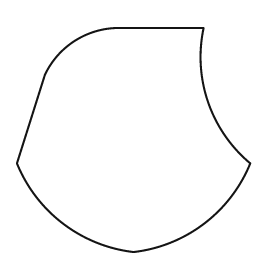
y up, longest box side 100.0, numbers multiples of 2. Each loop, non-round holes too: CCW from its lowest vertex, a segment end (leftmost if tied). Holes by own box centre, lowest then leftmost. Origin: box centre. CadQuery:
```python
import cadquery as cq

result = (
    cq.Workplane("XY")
    .moveTo(0.0, -48.0)
    .threePointArc((30.0, -36.0), (50.0, -10.0))
    .threePointArc((32.0, 16.0), (30.0, 48.0))
    .lineTo(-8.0, 48.0)
    .threePointArc((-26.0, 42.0), (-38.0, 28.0))
    .lineTo(-50.0, -10.0)
    .threePointArc((-30.0, -36.0), (0.0, -48.0))
    .close()
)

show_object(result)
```